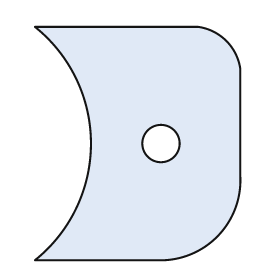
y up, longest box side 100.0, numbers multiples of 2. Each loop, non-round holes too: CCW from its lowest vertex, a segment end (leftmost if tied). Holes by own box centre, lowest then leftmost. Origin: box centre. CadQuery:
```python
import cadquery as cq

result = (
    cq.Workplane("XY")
    .moveTo(-44.0, -50.0)
    .lineTo(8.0, -50.0)
    .threePointArc((34.0, -40.0), (44.0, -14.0))
    .lineTo(44.0, 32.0)
    .threePointArc((38.0, 44.0), (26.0, 50.0))
    .lineTo(-44.0, 50.0)
    .threePointArc((-20.0, 0.0), (-44.0, -50.0))
    .close()
    .moveTo(10.0, 0.0)
    .circle(8.0)
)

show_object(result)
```